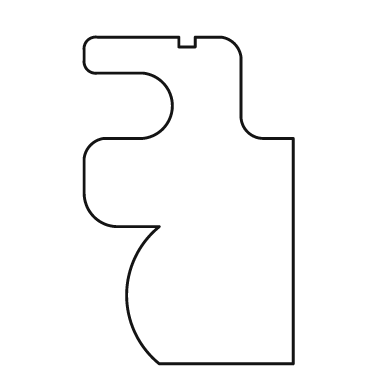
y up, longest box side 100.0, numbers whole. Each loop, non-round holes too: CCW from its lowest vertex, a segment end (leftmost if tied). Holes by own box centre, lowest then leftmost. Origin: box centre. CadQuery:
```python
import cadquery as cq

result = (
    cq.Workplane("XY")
    .moveTo(-9.0, -50.0)
    .lineTo(32.0, -50.0)
    .lineTo(32.0, 19.0)
    .lineTo(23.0, 19.0)
    .threePointArc((18.0, 21.0), (16.0, 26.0))
    .lineTo(16.0, 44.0)
    .threePointArc((14.0, 48.0), (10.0, 50.0))
    .lineTo(2.0, 50.0)
    .lineTo(2.0, 47.0)
    .lineTo(-3.0, 47.0)
    .lineTo(-3.0, 50.0)
    .lineTo(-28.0, 50.0)
    .threePointArc((-31.0, 49.0), (-32.0, 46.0))
    .lineTo(-32.0, 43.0)
    .threePointArc((-31.0, 40.0), (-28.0, 39.0))
    .lineTo(-14.0, 39.0)
    .threePointArc((-5.0, 29.0), (-14.0, 19.0))
    .lineTo(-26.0, 19.0)
    .threePointArc((-30.0, 17.0), (-32.0, 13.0))
    .lineTo(-32.0, 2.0)
    .threePointArc((-29.0, -5.0), (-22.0, -8.0))
    .lineTo(-9.0, -8.0)
    .threePointArc((-19.0, -29.0), (-9.0, -50.0))
    .close()
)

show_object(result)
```